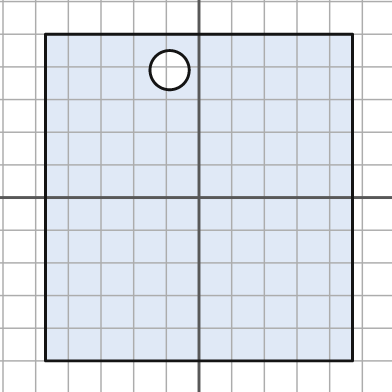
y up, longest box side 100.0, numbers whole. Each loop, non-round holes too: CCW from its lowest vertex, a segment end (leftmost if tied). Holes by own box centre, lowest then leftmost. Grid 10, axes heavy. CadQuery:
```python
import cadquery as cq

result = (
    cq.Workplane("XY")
    .moveTo(-47.0, -50.0)
    .lineTo(47.0, -50.0)
    .lineTo(47.0, 50.0)
    .lineTo(-47.0, 50.0)
    .close()
    .moveTo(-9.0, 39.0)
    .circle(6.0)
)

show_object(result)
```